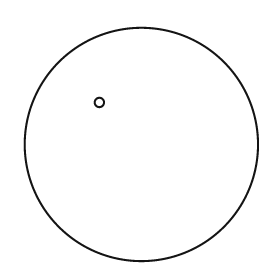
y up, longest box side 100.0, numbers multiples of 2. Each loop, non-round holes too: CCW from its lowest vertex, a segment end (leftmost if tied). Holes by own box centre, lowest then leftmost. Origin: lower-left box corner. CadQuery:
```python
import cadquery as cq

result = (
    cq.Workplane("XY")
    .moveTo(50.0, 50.0)
    .circle(50.0)
    .moveTo(32.0, 68.0)
    .circle(2.0)
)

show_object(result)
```